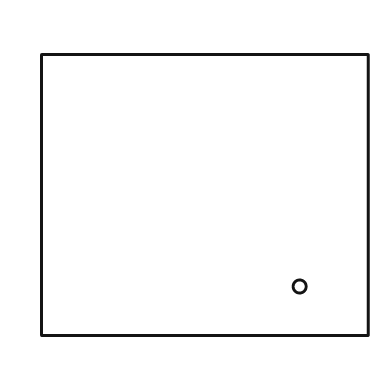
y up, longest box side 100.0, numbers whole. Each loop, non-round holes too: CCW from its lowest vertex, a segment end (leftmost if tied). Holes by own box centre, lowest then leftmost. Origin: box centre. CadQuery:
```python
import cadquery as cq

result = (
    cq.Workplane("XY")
    .moveTo(-50.0, -43.0)
    .lineTo(50.0, -43.0)
    .lineTo(50.0, 43.0)
    .lineTo(-50.0, 43.0)
    .close()
    .moveTo(29.0, -28.0)
    .circle(2.0)
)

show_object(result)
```